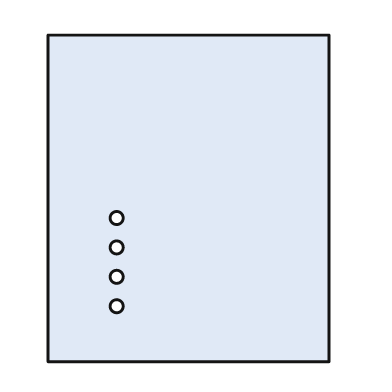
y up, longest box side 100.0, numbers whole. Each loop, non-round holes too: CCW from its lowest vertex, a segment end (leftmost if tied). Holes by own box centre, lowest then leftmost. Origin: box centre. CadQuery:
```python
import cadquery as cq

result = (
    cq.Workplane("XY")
    .moveTo(-43.0, -50.0)
    .lineTo(43.0, -50.0)
    .lineTo(43.0, 50.0)
    .lineTo(-43.0, 50.0)
    .close()
    .moveTo(-22.0, -33.0)
    .circle(2.0)
    .moveTo(-22.0, -24.0)
    .circle(2.0)
    .moveTo(-22.0, -15.0)
    .circle(2.0)
    .moveTo(-22.0, -6.0)
    .circle(2.0)
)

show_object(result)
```